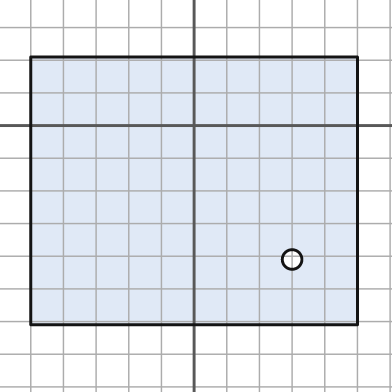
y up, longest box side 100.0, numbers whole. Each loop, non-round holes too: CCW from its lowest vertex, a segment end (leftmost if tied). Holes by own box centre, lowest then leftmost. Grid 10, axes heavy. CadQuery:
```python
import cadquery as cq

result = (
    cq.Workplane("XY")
    .moveTo(-50.0, -61.0)
    .lineTo(50.0, -61.0)
    .lineTo(50.0, 21.0)
    .lineTo(-50.0, 21.0)
    .close()
    .moveTo(30.0, -41.0)
    .circle(3.0)
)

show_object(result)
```